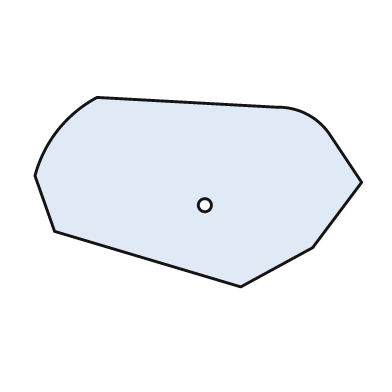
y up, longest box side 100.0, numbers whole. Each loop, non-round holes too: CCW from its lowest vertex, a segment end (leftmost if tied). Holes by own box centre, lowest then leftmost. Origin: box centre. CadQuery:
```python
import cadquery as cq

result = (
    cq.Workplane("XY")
    .moveTo(13.0, -29.0)
    .lineTo(35.0, -17.0)
    .lineTo(50.0, 3.0)
    .lineTo(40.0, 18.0)
    .threePointArc((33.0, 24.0), (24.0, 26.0))
    .lineTo(-31.0, 29.0)
    .threePointArc((-43.0, 19.0), (-50.0, 5.0))
    .lineTo(-44.0, -12.0)
    .close()
    .moveTo(2.0, -4.0)
    .circle(2.0)
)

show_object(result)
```